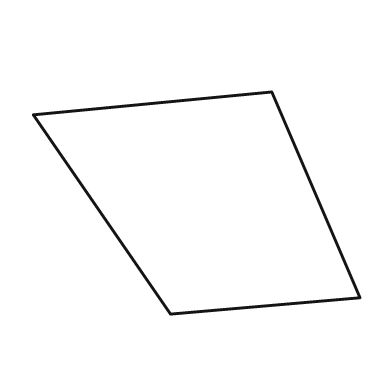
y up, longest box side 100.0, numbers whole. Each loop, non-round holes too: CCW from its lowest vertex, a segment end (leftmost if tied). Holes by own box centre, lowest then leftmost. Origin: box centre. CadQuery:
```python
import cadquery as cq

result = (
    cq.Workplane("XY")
    .moveTo(-8.0, -34.0)
    .lineTo(50.0, -29.0)
    .lineTo(23.0, 34.0)
    .lineTo(-50.0, 27.0)
    .close()
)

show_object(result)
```